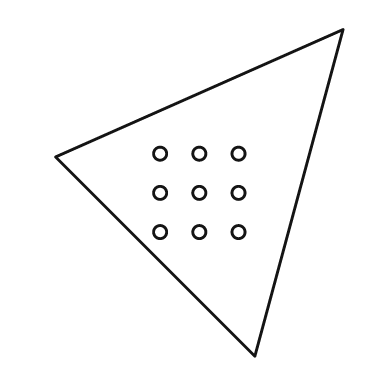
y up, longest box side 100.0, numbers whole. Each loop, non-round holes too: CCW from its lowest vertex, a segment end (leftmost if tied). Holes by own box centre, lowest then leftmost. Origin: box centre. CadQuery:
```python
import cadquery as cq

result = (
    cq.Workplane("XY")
    .moveTo(17.0, -50.0)
    .lineTo(44.0, 50.0)
    .lineTo(-44.0, 11.0)
    .close()
    .moveTo(-12.0, -12.0)
    .circle(2.0)
    .moveTo(0.0, -12.0)
    .circle(2.0)
    .moveTo(12.0, -12.0)
    .circle(2.0)
    .moveTo(-12.0, 0.0)
    .circle(2.0)
    .moveTo(0.0, 0.0)
    .circle(2.0)
    .moveTo(12.0, 0.0)
    .circle(2.0)
    .moveTo(-12.0, 12.0)
    .circle(2.0)
    .moveTo(0.0, 12.0)
    .circle(2.0)
    .moveTo(12.0, 12.0)
    .circle(2.0)
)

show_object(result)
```